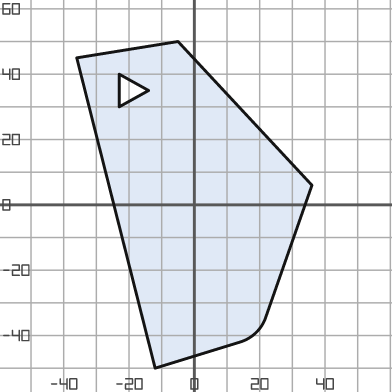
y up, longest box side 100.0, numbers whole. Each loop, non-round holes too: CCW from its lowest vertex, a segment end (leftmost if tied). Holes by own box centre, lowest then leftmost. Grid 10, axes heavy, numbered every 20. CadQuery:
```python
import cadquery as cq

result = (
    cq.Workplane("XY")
    .moveTo(-12.0, -50.0)
    .lineTo(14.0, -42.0)
    .threePointArc((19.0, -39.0), (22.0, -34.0))
    .lineTo(36.0, 6.0)
    .lineTo(-5.0, 50.0)
    .lineTo(-36.0, 45.0)
    .close()
    .moveTo(-23.0, 30.0)
    .lineTo(-14.0, 35.0)
    .lineTo(-23.0, 40.0)
    .close()
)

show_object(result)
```